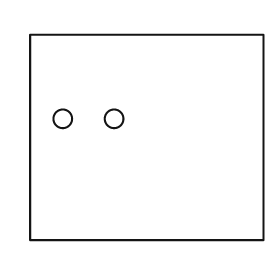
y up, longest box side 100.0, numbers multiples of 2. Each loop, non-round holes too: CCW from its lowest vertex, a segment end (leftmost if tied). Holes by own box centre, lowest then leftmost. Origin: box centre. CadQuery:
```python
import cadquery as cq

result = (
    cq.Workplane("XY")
    .moveTo(-50.0, -44.0)
    .lineTo(50.0, -44.0)
    .lineTo(50.0, 44.0)
    .lineTo(-50.0, 44.0)
    .close()
    .moveTo(-36.0, 8.0)
    .circle(4.0)
    .moveTo(-14.0, 8.0)
    .circle(4.0)
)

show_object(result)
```